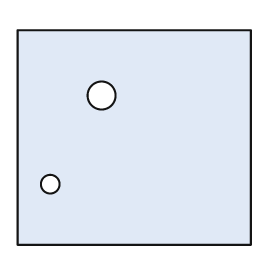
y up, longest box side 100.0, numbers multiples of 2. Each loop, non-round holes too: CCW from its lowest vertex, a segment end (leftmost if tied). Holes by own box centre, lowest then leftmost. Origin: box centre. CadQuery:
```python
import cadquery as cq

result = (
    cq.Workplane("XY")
    .moveTo(-50.0, -46.0)
    .lineTo(50.0, -46.0)
    .lineTo(50.0, 46.0)
    .lineTo(-50.0, 46.0)
    .close()
    .moveTo(-36.0, -20.0)
    .circle(4.0)
    .moveTo(-14.0, 18.0)
    .circle(6.0)
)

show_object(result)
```